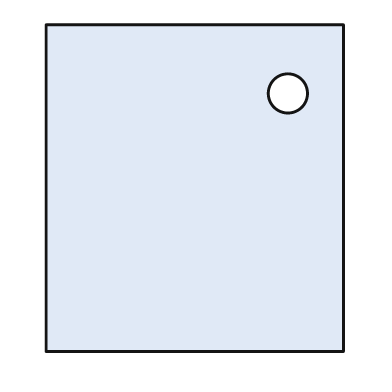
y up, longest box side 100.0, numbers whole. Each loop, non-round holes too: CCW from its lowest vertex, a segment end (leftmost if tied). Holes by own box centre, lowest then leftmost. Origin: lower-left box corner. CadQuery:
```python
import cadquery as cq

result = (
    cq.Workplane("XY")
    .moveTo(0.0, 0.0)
    .lineTo(91.0, 0.0)
    .lineTo(91.0, 100.0)
    .lineTo(0.0, 100.0)
    .close()
    .moveTo(74.0, 79.0)
    .circle(6.0)
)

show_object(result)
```